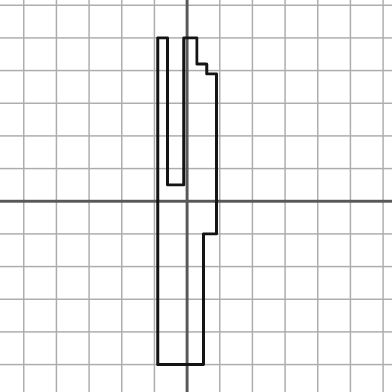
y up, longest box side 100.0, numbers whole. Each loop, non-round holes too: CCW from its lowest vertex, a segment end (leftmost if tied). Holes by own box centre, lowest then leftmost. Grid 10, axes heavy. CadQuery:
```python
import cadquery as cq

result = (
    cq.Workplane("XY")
    .moveTo(-9.0, -50.0)
    .lineTo(5.0, -50.0)
    .lineTo(5.0, -10.0)
    .lineTo(9.0, -10.0)
    .lineTo(9.0, 39.0)
    .lineTo(6.0, 39.0)
    .lineTo(6.0, 42.0)
    .lineTo(3.0, 42.0)
    .lineTo(3.0, 50.0)
    .lineTo(-1.0, 50.0)
    .lineTo(-1.0, 5.0)
    .lineTo(-6.0, 5.0)
    .lineTo(-6.0, 50.0)
    .lineTo(-9.0, 50.0)
    .close()
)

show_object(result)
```